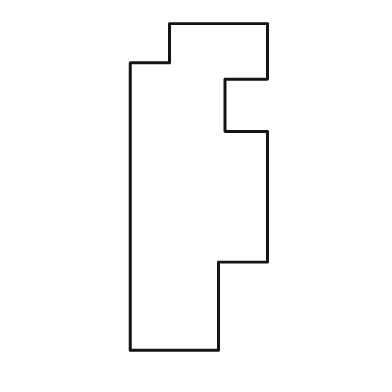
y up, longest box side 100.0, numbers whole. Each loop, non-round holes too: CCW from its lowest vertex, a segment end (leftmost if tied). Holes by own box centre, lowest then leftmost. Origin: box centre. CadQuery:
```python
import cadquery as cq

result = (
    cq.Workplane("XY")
    .moveTo(-21.0, -50.0)
    .lineTo(6.0, -50.0)
    .lineTo(6.0, -23.0)
    .lineTo(21.0, -23.0)
    .lineTo(21.0, 17.0)
    .lineTo(8.0, 17.0)
    .lineTo(8.0, 33.0)
    .lineTo(21.0, 33.0)
    .lineTo(21.0, 50.0)
    .lineTo(-9.0, 50.0)
    .lineTo(-9.0, 38.0)
    .lineTo(-21.0, 38.0)
    .close()
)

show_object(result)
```